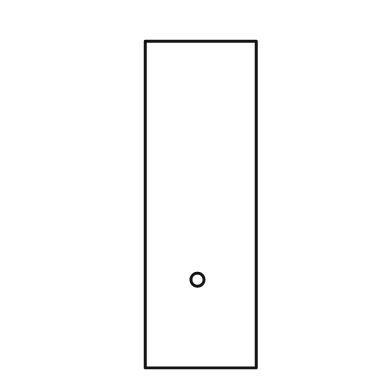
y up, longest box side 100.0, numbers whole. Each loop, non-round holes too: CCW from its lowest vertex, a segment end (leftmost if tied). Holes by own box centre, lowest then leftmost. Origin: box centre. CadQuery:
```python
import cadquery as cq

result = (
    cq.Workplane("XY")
    .moveTo(-17.0, -50.0)
    .lineTo(17.0, -50.0)
    .lineTo(17.0, 50.0)
    .lineTo(-17.0, 50.0)
    .close()
    .moveTo(-1.0, -23.0)
    .circle(2.0)
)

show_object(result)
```